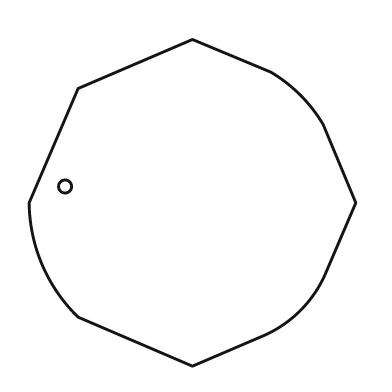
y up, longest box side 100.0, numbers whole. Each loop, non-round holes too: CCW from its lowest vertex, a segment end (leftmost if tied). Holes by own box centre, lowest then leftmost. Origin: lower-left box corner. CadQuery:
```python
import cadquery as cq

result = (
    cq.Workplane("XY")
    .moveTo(50.0, 0.0)
    .lineTo(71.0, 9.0)
    .threePointArc((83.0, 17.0), (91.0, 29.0))
    .lineTo(100.0, 50.0)
    .lineTo(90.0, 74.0)
    .threePointArc((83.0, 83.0), (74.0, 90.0))
    .lineTo(50.0, 100.0)
    .lineTo(15.0, 85.0)
    .lineTo(0.0, 50.0)
    .threePointArc((4.0, 31.0), (15.0, 15.0))
    .close()
    .moveTo(11.0, 55.0)
    .circle(2.0)
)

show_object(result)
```